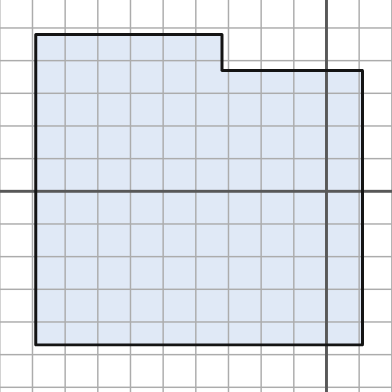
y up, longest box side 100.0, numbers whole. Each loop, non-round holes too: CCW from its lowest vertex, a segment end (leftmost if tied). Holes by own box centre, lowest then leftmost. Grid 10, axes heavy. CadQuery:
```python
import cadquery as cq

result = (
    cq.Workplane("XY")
    .moveTo(-89.0, -47.0)
    .lineTo(11.0, -47.0)
    .lineTo(11.0, 37.0)
    .lineTo(-32.0, 37.0)
    .lineTo(-32.0, 48.0)
    .lineTo(-89.0, 48.0)
    .close()
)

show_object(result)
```